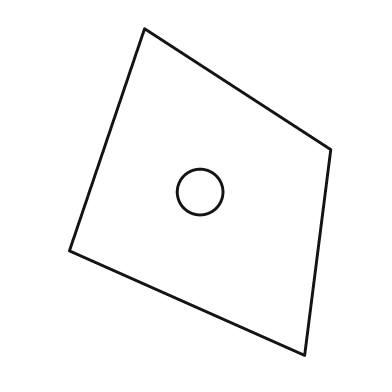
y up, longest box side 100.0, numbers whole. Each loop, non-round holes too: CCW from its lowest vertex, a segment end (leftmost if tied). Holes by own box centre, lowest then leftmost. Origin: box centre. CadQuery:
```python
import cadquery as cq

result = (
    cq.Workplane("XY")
    .moveTo(32.0, -50.0)
    .lineTo(40.0, 13.0)
    .lineTo(-17.0, 50.0)
    .lineTo(-40.0, -18.0)
    .close()
    .moveTo(0.0, 0.0)
    .circle(7.0)
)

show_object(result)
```